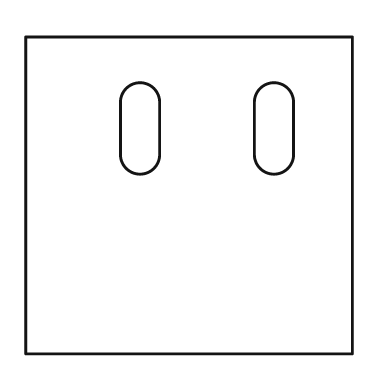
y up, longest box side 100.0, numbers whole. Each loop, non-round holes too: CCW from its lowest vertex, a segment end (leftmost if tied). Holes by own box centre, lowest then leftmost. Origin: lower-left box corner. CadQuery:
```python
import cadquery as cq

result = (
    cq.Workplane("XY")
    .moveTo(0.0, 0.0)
    .lineTo(100.0, 0.0)
    .lineTo(100.0, 97.0)
    .lineTo(0.0, 97.0)
    .close()
    .moveTo(29.0, 61.0)
    .threePointArc((35.0, 55.0), (41.0, 61.0))
    .lineTo(41.0, 77.0)
    .threePointArc((35.0, 83.0), (29.0, 77.0))
    .close()
    .moveTo(70.0, 61.0)
    .threePointArc((76.0, 55.0), (82.0, 61.0))
    .lineTo(82.0, 77.0)
    .threePointArc((76.0, 83.0), (70.0, 77.0))
    .close()
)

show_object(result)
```